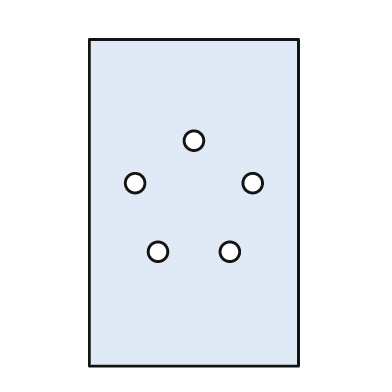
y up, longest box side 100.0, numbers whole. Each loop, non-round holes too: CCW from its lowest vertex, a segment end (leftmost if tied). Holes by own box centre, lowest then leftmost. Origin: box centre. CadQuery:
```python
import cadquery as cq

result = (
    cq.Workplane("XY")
    .moveTo(-32.0, -50.0)
    .lineTo(32.0, -50.0)
    .lineTo(32.0, 50.0)
    .lineTo(-32.0, 50.0)
    .close()
    .moveTo(-11.0, -15.0)
    .circle(3.0)
    .moveTo(11.0, -15.0)
    .circle(3.0)
    .moveTo(-18.0, 6.0)
    .circle(3.0)
    .moveTo(18.0, 6.0)
    .circle(3.0)
    .moveTo(0.0, 19.0)
    .circle(3.0)
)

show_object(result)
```